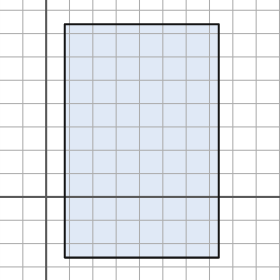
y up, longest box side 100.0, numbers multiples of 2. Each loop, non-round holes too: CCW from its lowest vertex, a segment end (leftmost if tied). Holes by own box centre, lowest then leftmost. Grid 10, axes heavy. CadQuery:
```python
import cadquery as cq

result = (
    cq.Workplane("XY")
    .moveTo(8.0, -26.0)
    .lineTo(74.0, -26.0)
    .lineTo(74.0, 74.0)
    .lineTo(8.0, 74.0)
    .close()
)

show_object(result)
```